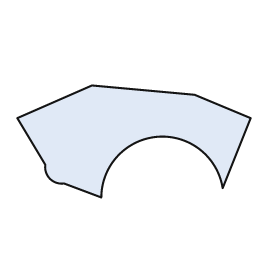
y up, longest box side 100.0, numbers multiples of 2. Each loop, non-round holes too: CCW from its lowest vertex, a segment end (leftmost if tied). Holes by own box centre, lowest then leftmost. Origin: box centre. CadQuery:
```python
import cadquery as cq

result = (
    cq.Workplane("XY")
    .moveTo(-14.0, -24.0)
    .threePointArc((10.0, 2.0), (38.0, -20.0))
    .lineTo(50.0, 10.0)
    .lineTo(26.0, 20.0)
    .lineTo(-18.0, 24.0)
    .lineTo(-50.0, 10.0)
    .lineTo(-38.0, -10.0)
    .threePointArc((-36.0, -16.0), (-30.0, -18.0))
    .close()
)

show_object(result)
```